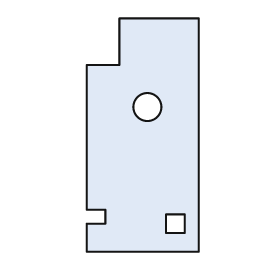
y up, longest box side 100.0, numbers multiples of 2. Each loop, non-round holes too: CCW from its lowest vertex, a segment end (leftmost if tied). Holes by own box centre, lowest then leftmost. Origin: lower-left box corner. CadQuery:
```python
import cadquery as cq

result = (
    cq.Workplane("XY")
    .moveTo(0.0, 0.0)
    .lineTo(48.0, 0.0)
    .lineTo(48.0, 100.0)
    .lineTo(14.0, 100.0)
    .lineTo(14.0, 80.0)
    .lineTo(0.0, 80.0)
    .lineTo(0.0, 18.0)
    .lineTo(8.0, 18.0)
    .lineTo(8.0, 12.0)
    .lineTo(0.0, 12.0)
    .close()
    .moveTo(34.0, 8.0)
    .lineTo(42.0, 8.0)
    .lineTo(42.0, 16.0)
    .lineTo(34.0, 16.0)
    .close()
    .moveTo(26.0, 62.0)
    .circle(6.0)
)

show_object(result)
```